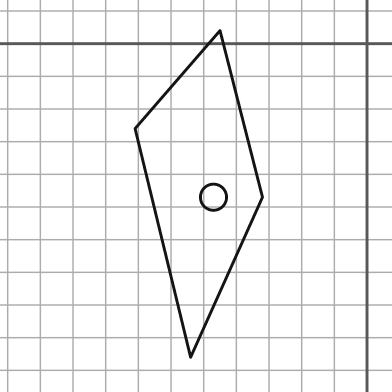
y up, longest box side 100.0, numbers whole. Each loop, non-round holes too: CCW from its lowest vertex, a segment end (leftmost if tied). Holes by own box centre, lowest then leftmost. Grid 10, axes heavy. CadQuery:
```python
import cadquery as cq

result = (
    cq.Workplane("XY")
    .moveTo(-54.0, -96.0)
    .lineTo(-32.0, -47.0)
    .lineTo(-45.0, 4.0)
    .lineTo(-71.0, -26.0)
    .close()
    .moveTo(-47.0, -47.0)
    .circle(4.0)
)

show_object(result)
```